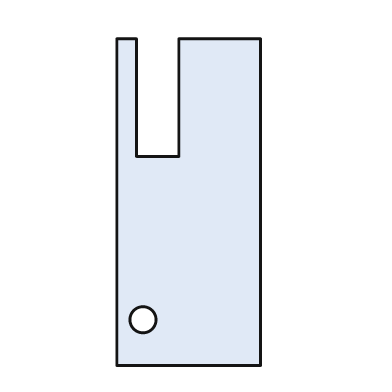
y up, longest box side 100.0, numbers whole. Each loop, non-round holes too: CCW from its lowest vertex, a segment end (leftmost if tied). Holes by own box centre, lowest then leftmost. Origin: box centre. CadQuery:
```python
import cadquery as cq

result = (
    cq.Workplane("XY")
    .moveTo(-22.0, -50.0)
    .lineTo(22.0, -50.0)
    .lineTo(22.0, 50.0)
    .lineTo(-3.0, 50.0)
    .lineTo(-3.0, 14.0)
    .lineTo(-16.0, 14.0)
    .lineTo(-16.0, 50.0)
    .lineTo(-22.0, 50.0)
    .close()
    .moveTo(-14.0, -36.0)
    .circle(4.0)
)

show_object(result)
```